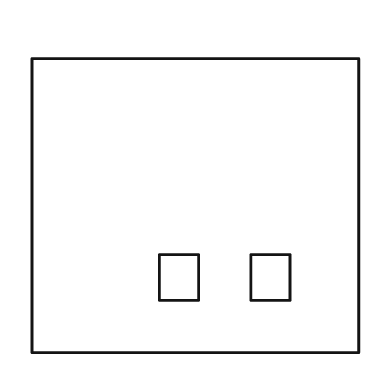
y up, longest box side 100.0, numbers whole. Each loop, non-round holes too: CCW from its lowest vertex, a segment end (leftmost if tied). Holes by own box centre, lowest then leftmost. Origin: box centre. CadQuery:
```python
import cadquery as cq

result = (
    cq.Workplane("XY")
    .moveTo(-50.0, -45.0)
    .lineTo(50.0, -45.0)
    .lineTo(50.0, 45.0)
    .lineTo(-50.0, 45.0)
    .close()
    .moveTo(-11.0, -29.0)
    .lineTo(1.0, -29.0)
    .lineTo(1.0, -15.0)
    .lineTo(-11.0, -15.0)
    .close()
    .moveTo(17.0, -29.0)
    .lineTo(29.0, -29.0)
    .lineTo(29.0, -15.0)
    .lineTo(17.0, -15.0)
    .close()
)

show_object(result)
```